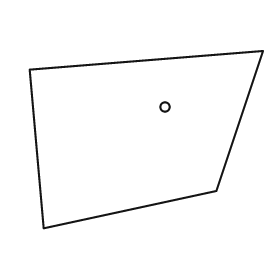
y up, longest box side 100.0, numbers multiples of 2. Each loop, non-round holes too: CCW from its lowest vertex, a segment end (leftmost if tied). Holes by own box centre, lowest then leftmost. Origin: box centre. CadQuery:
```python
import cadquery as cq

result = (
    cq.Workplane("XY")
    .moveTo(-44.0, -38.0)
    .lineTo(30.0, -22.0)
    .lineTo(50.0, 38.0)
    .lineTo(-50.0, 30.0)
    .close()
    .moveTo(8.0, 14.0)
    .circle(2.0)
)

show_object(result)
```